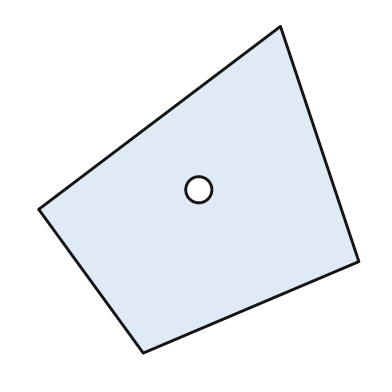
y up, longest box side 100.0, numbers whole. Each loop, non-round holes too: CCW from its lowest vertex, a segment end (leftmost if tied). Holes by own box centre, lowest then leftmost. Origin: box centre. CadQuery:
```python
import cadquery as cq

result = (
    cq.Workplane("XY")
    .moveTo(-17.0, -50.0)
    .lineTo(49.0, -22.0)
    .lineTo(25.0, 50.0)
    .lineTo(-49.0, -6.0)
    .close()
    .moveTo(0.0, 0.0)
    .circle(4.0)
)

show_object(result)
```